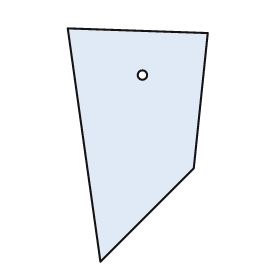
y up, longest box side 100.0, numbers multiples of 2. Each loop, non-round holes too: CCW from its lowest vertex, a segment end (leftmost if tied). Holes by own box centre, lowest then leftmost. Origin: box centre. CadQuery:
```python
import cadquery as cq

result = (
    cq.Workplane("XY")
    .moveTo(-16.0, -50.0)
    .lineTo(24.0, -10.0)
    .lineTo(30.0, 48.0)
    .lineTo(-30.0, 50.0)
    .close()
    .moveTo(2.0, 30.0)
    .circle(2.0)
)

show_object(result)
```